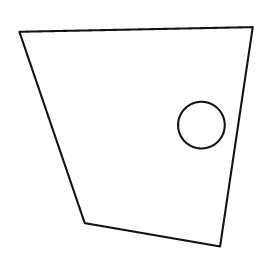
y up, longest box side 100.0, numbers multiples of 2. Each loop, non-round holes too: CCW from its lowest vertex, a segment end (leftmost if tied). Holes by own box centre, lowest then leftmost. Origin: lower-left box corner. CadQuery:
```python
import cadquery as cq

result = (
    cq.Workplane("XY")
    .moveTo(86.0, 0.0)
    .lineTo(100.0, 94.0)
    .lineTo(0.0, 92.0)
    .lineTo(28.0, 10.0)
    .close()
    .moveTo(78.0, 52.0)
    .circle(10.0)
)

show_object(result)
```